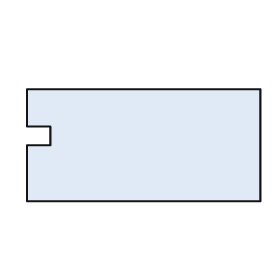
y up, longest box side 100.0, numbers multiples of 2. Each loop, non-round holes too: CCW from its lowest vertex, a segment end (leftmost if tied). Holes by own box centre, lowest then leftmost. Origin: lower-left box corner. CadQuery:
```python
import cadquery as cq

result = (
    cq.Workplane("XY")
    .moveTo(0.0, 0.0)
    .lineTo(100.0, 0.0)
    .lineTo(100.0, 48.0)
    .lineTo(0.0, 48.0)
    .lineTo(0.0, 32.0)
    .lineTo(10.0, 32.0)
    .lineTo(10.0, 24.0)
    .lineTo(0.0, 24.0)
    .close()
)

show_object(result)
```